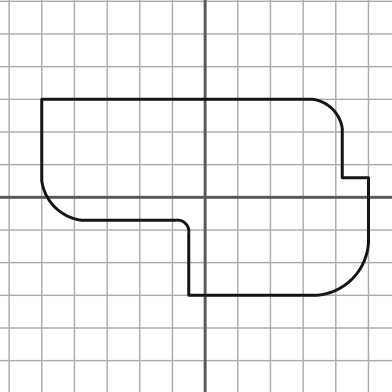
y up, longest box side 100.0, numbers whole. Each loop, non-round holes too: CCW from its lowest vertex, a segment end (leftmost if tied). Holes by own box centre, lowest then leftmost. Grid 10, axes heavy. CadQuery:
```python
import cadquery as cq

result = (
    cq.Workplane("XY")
    .moveTo(-5.0, -30.0)
    .lineTo(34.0, -30.0)
    .threePointArc((45.0, -25.0), (50.0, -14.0))
    .lineTo(50.0, 6.0)
    .lineTo(42.0, 6.0)
    .lineTo(42.0, 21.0)
    .threePointArc((39.0, 27.0), (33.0, 30.0))
    .lineTo(-50.0, 30.0)
    .lineTo(-50.0, 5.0)
    .threePointArc((-46.0, -3.0), (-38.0, -7.0))
    .lineTo(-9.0, -7.0)
    .threePointArc((-6.0, -8.0), (-5.0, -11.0))
    .close()
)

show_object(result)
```